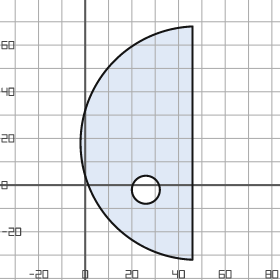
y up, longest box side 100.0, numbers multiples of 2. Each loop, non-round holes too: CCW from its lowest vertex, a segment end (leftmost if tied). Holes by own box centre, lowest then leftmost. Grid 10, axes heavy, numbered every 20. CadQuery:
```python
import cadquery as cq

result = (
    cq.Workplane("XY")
    .moveTo(46.0, -32.0)
    .lineTo(46.0, 68.0)
    .threePointArc((-2.0, 18.0), (46.0, -32.0))
    .close()
    .moveTo(26.0, -2.0)
    .circle(6.0)
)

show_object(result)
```